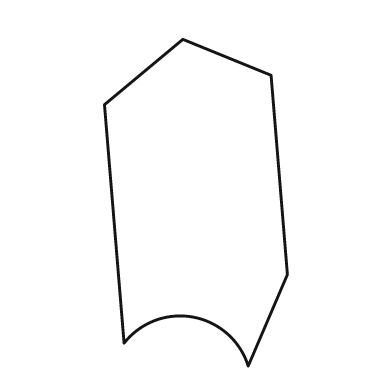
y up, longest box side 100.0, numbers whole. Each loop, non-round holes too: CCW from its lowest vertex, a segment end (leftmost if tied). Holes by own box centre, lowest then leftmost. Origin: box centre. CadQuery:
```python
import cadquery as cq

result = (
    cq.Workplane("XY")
    .moveTo(16.0, -50.0)
    .lineTo(28.0, -22.0)
    .lineTo(23.0, 39.0)
    .lineTo(-4.0, 50.0)
    .lineTo(-28.0, 30.0)
    .lineTo(-22.0, -43.0)
    .threePointArc((-1.0, -35.0), (16.0, -50.0))
    .close()
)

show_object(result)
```